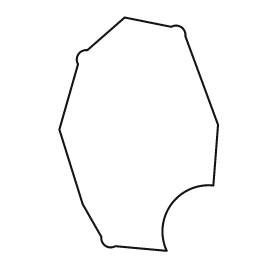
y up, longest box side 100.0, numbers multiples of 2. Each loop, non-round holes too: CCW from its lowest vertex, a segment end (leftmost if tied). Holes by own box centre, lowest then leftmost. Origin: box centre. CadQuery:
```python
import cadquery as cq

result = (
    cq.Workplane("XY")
    .moveTo(12.0, -50.0)
    .threePointArc((14.0, -30.0), (32.0, -22.0))
    .lineTo(34.0, 4.0)
    .lineTo(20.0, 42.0)
    .threePointArc((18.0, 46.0), (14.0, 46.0))
    .lineTo(-6.0, 50.0)
    .lineTo(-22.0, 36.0)
    .threePointArc((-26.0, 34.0), (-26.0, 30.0))
    .lineTo(-34.0, 2.0)
    .lineTo(-24.0, -30.0)
    .lineTo(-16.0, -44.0)
    .threePointArc((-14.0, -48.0), (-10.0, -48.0))
    .close()
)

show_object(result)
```